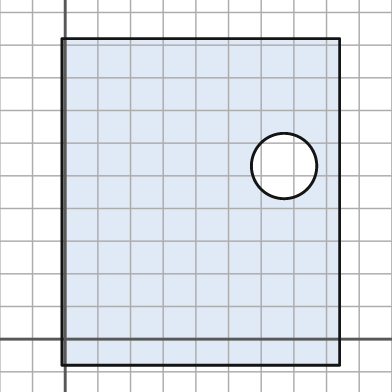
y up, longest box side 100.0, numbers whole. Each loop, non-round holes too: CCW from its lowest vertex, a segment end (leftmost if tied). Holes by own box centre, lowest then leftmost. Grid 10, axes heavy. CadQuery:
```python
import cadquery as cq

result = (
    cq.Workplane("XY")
    .moveTo(-1.0, -8.0)
    .lineTo(84.0, -8.0)
    .lineTo(84.0, 92.0)
    .lineTo(-1.0, 92.0)
    .close()
    .moveTo(67.0, 53.0)
    .circle(10.0)
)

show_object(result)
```